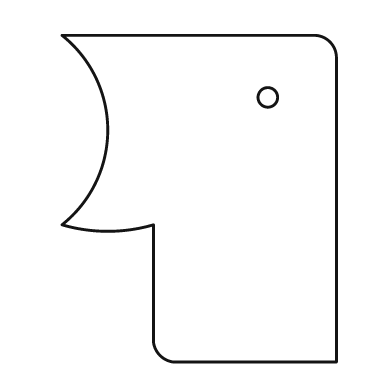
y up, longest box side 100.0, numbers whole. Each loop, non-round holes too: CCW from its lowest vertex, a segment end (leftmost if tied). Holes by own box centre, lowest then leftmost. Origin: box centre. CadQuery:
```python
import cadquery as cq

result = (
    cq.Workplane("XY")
    .moveTo(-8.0, -50.0)
    .lineTo(42.0, -50.0)
    .lineTo(42.0, 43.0)
    .threePointArc((40.0, 48.0), (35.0, 50.0))
    .lineTo(-42.0, 50.0)
    .threePointArc((-28.0, 21.0), (-42.0, -8.0))
    .threePointArc((-28.0, -10.0), (-14.0, -8.0))
    .lineTo(-14.0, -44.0)
    .threePointArc((-12.0, -48.0), (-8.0, -50.0))
    .close()
    .moveTo(21.0, 31.0)
    .circle(3.0)
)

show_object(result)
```